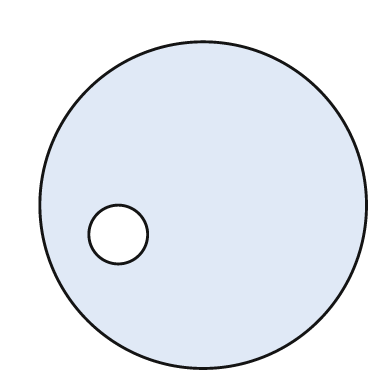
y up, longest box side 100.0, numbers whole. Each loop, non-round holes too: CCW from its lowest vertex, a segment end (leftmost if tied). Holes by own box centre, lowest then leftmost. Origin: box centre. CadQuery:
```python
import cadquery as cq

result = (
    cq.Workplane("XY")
    .moveTo(0.0, 0.0)
    .circle(50.0)
    .moveTo(-26.0, -9.0)
    .circle(9.0)
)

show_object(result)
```